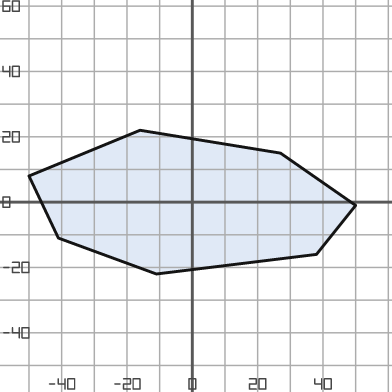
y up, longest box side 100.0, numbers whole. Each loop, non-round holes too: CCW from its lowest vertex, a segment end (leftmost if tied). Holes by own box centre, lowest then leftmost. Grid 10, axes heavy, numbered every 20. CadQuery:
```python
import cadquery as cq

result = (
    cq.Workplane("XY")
    .moveTo(-11.0, -22.0)
    .lineTo(38.0, -16.0)
    .lineTo(50.0, -1.0)
    .lineTo(27.0, 15.0)
    .lineTo(-16.0, 22.0)
    .lineTo(-50.0, 8.0)
    .lineTo(-41.0, -11.0)
    .close()
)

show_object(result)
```